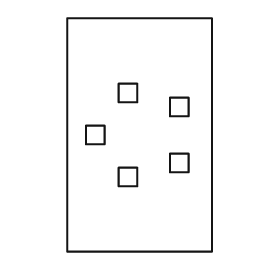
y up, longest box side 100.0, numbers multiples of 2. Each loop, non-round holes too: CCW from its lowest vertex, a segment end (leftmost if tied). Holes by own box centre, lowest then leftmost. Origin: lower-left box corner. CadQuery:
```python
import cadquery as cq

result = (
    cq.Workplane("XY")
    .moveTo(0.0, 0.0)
    .lineTo(62.0, 0.0)
    .lineTo(62.0, 100.0)
    .lineTo(0.0, 100.0)
    .close()
    .moveTo(22.0, 28.0)
    .lineTo(30.0, 28.0)
    .lineTo(30.0, 36.0)
    .lineTo(22.0, 36.0)
    .close()
    .moveTo(44.0, 34.0)
    .lineTo(52.0, 34.0)
    .lineTo(52.0, 42.0)
    .lineTo(44.0, 42.0)
    .close()
    .moveTo(8.0, 46.0)
    .lineTo(16.0, 46.0)
    .lineTo(16.0, 54.0)
    .lineTo(8.0, 54.0)
    .close()
    .moveTo(44.0, 58.0)
    .lineTo(52.0, 58.0)
    .lineTo(52.0, 66.0)
    .lineTo(44.0, 66.0)
    .close()
    .moveTo(22.0, 64.0)
    .lineTo(30.0, 64.0)
    .lineTo(30.0, 72.0)
    .lineTo(22.0, 72.0)
    .close()
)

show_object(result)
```